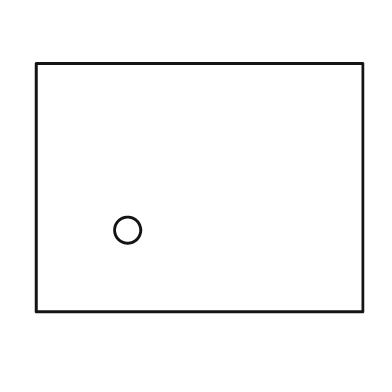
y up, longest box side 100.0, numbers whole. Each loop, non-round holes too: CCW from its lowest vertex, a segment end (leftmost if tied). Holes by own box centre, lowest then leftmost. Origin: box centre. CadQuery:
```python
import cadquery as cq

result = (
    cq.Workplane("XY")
    .moveTo(-50.0, -38.0)
    .lineTo(50.0, -38.0)
    .lineTo(50.0, 38.0)
    .lineTo(-50.0, 38.0)
    .close()
    .moveTo(-22.0, -13.0)
    .circle(4.0)
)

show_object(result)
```